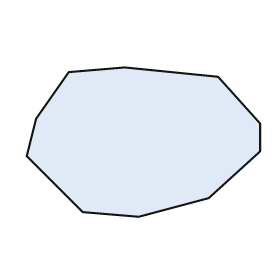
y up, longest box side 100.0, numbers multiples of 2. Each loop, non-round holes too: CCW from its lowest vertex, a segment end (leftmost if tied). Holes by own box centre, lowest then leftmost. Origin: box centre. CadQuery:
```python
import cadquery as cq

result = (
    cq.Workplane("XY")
    .moveTo(-2.0, -32.0)
    .lineTo(28.0, -24.0)
    .lineTo(50.0, -4.0)
    .lineTo(50.0, 8.0)
    .lineTo(32.0, 28.0)
    .lineTo(-8.0, 32.0)
    .lineTo(-32.0, 30.0)
    .lineTo(-46.0, 10.0)
    .lineTo(-50.0, -6.0)
    .lineTo(-26.0, -30.0)
    .close()
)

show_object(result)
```